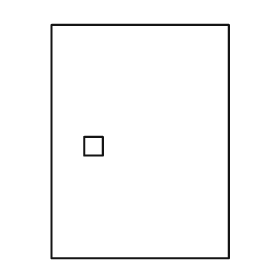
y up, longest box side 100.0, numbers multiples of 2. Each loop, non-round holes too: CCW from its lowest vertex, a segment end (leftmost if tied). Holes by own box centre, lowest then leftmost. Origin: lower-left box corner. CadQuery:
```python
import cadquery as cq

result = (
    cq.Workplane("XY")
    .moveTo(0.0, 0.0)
    .lineTo(76.0, 0.0)
    .lineTo(76.0, 100.0)
    .lineTo(0.0, 100.0)
    .close()
    .moveTo(14.0, 44.0)
    .lineTo(22.0, 44.0)
    .lineTo(22.0, 52.0)
    .lineTo(14.0, 52.0)
    .close()
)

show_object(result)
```